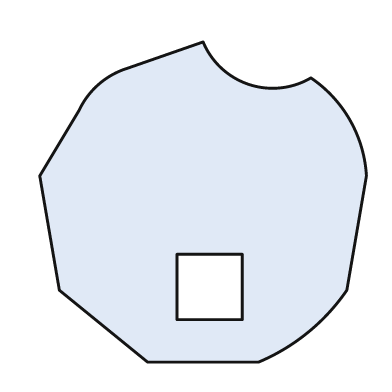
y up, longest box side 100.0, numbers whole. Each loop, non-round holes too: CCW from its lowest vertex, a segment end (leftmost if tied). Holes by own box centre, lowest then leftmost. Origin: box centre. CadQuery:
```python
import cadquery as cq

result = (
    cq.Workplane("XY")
    .moveTo(-17.0, -49.0)
    .lineTo(17.0, -49.0)
    .threePointArc((32.0, -40.0), (44.0, -27.0))
    .lineTo(50.0, 8.0)
    .threePointArc((45.0, 25.0), (33.0, 38.0))
    .threePointArc((14.0, 36.0), (0.0, 49.0))
    .lineTo(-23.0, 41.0)
    .threePointArc((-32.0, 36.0), (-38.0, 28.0))
    .lineTo(-50.0, 8.0)
    .lineTo(-44.0, -27.0)
    .close()
    .moveTo(-8.0, -36.0)
    .lineTo(12.0, -36.0)
    .lineTo(12.0, -16.0)
    .lineTo(-8.0, -16.0)
    .close()
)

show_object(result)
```